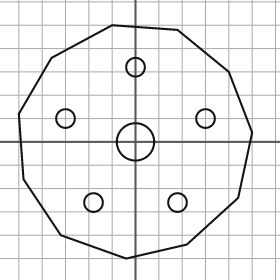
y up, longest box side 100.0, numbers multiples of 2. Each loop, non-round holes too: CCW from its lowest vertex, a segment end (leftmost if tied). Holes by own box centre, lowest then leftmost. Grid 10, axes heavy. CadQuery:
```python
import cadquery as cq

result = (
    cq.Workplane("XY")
    .moveTo(-4.0, -50.0)
    .lineTo(22.0, -44.0)
    .lineTo(44.0, -24.0)
    .lineTo(50.0, 4.0)
    .lineTo(40.0, 30.0)
    .lineTo(18.0, 48.0)
    .lineTo(-10.0, 50.0)
    .lineTo(-36.0, 36.0)
    .lineTo(-50.0, 12.0)
    .lineTo(-48.0, -16.0)
    .lineTo(-32.0, -40.0)
    .close()
    .moveTo(-18.0, -26.0)
    .circle(4.0)
    .moveTo(18.0, -26.0)
    .circle(4.0)
    .moveTo(0.0, 0.0)
    .circle(8.0)
    .moveTo(-30.0, 10.0)
    .circle(4.0)
    .moveTo(30.0, 10.0)
    .circle(4.0)
    .moveTo(0.0, 32.0)
    .circle(4.0)
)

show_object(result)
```